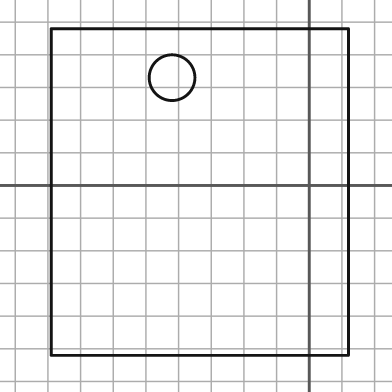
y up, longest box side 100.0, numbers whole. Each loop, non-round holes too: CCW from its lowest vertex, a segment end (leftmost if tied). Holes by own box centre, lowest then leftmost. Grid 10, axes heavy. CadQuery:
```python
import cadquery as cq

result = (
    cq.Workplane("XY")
    .moveTo(-79.0, -52.0)
    .lineTo(12.0, -52.0)
    .lineTo(12.0, 48.0)
    .lineTo(-79.0, 48.0)
    .close()
    .moveTo(-42.0, 33.0)
    .circle(7.0)
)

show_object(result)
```